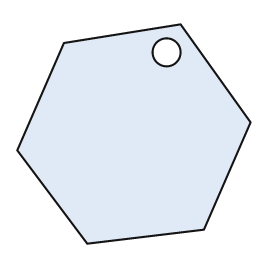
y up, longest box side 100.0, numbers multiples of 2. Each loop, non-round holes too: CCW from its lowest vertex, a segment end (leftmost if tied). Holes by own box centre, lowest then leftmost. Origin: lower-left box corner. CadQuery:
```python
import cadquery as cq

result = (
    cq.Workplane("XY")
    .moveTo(30.0, 0.0)
    .lineTo(80.0, 6.0)
    .lineTo(100.0, 52.0)
    .lineTo(70.0, 94.0)
    .lineTo(20.0, 86.0)
    .lineTo(0.0, 40.0)
    .close()
    .moveTo(64.0, 82.0)
    .circle(6.0)
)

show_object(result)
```